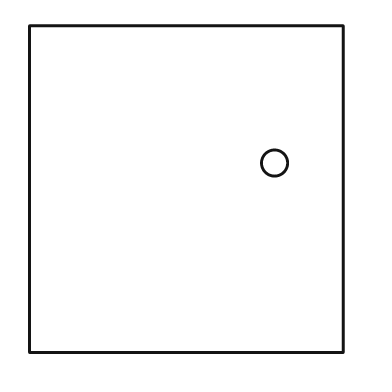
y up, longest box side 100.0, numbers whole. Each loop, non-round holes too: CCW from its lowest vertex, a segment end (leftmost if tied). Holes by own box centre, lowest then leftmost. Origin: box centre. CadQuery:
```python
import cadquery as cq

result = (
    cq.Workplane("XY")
    .moveTo(-48.0, -50.0)
    .lineTo(48.0, -50.0)
    .lineTo(48.0, 50.0)
    .lineTo(-48.0, 50.0)
    .close()
    .moveTo(27.0, 8.0)
    .circle(4.0)
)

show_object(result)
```